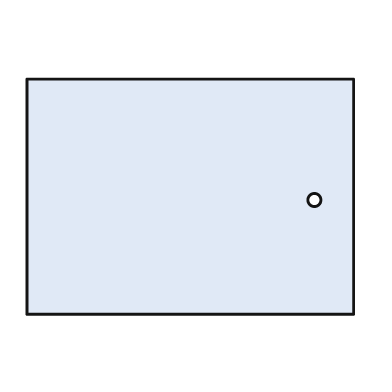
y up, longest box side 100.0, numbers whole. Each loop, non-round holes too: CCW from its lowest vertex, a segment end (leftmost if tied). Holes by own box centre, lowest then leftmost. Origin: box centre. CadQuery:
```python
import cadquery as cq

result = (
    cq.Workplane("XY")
    .moveTo(-50.0, -36.0)
    .lineTo(50.0, -36.0)
    .lineTo(50.0, 36.0)
    .lineTo(-50.0, 36.0)
    .close()
    .moveTo(38.0, -1.0)
    .circle(2.0)
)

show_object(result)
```